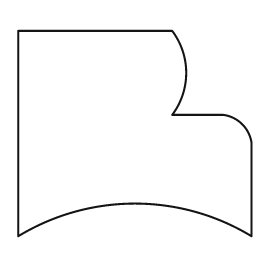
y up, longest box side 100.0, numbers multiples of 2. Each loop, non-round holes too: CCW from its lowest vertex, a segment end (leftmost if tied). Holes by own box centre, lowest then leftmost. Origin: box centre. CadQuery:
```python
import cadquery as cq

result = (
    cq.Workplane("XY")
    .moveTo(-50.0, -44.0)
    .threePointArc((0.0, -30.0), (50.0, -44.0))
    .lineTo(50.0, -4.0)
    .threePointArc((46.0, 4.0), (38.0, 8.0))
    .lineTo(16.0, 8.0)
    .threePointArc((22.0, 26.0), (16.0, 44.0))
    .lineTo(-50.0, 44.0)
    .close()
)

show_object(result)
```